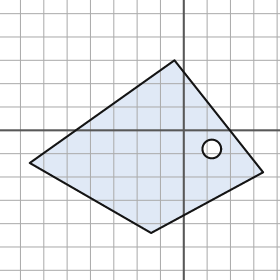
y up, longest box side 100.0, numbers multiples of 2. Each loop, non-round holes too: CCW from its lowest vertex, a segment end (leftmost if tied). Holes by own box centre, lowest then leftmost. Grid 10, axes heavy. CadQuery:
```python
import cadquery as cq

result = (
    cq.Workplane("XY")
    .moveTo(-14.0, -44.0)
    .lineTo(34.0, -18.0)
    .lineTo(-4.0, 30.0)
    .lineTo(-66.0, -14.0)
    .close()
    .moveTo(12.0, -8.0)
    .circle(4.0)
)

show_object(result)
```